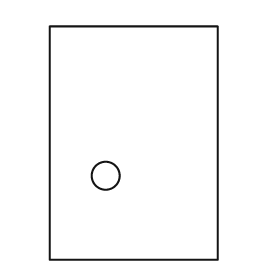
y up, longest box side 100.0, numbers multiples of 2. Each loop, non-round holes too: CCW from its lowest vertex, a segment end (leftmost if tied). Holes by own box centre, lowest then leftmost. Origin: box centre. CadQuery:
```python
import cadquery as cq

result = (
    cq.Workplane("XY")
    .moveTo(-36.0, -50.0)
    .lineTo(36.0, -50.0)
    .lineTo(36.0, 50.0)
    .lineTo(-36.0, 50.0)
    .close()
    .moveTo(-12.0, -14.0)
    .circle(6.0)
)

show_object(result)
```